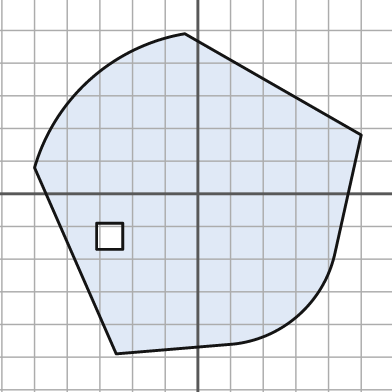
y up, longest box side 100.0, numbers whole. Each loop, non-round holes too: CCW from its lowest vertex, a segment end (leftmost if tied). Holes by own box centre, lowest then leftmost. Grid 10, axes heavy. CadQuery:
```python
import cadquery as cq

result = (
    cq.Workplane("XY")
    .moveTo(-25.0, -49.0)
    .lineTo(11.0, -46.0)
    .threePointArc((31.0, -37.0), (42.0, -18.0))
    .lineTo(50.0, 18.0)
    .lineTo(-4.0, 49.0)
    .threePointArc((-33.0, 35.0), (-50.0, 8.0))
    .close()
    .moveTo(-31.0, -17.0)
    .lineTo(-23.0, -17.0)
    .lineTo(-23.0, -9.0)
    .lineTo(-31.0, -9.0)
    .close()
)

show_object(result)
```